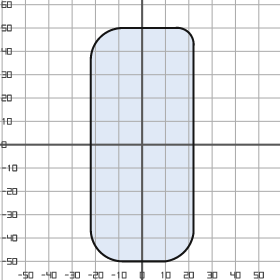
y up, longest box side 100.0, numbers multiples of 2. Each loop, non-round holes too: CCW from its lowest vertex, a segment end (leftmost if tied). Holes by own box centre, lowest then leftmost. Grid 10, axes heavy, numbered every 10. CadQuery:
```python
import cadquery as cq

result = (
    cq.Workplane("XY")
    .moveTo(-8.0, -50.0)
    .lineTo(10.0, -50.0)
    .threePointArc((18.0, -46.0), (22.0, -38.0))
    .lineTo(22.0, 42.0)
    .threePointArc((20.0, 48.0), (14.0, 50.0))
    .lineTo(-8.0, 50.0)
    .threePointArc((-18.0, 46.0), (-22.0, 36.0))
    .lineTo(-22.0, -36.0)
    .threePointArc((-18.0, -46.0), (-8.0, -50.0))
    .close()
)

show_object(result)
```